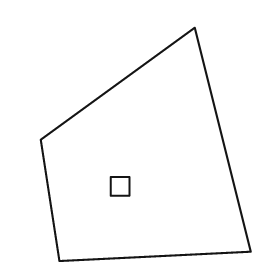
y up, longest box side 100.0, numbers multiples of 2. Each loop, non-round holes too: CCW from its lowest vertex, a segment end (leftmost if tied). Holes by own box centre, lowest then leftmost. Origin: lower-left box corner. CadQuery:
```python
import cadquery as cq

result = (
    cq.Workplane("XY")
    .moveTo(8.0, 0.0)
    .lineTo(90.0, 4.0)
    .lineTo(66.0, 100.0)
    .lineTo(0.0, 52.0)
    .close()
    .moveTo(30.0, 28.0)
    .lineTo(38.0, 28.0)
    .lineTo(38.0, 36.0)
    .lineTo(30.0, 36.0)
    .close()
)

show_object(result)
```